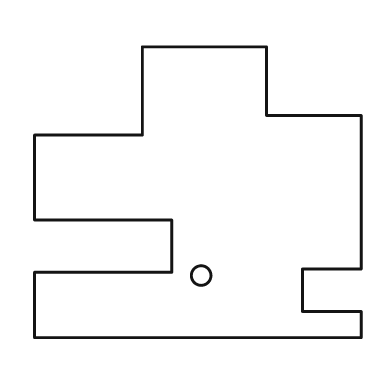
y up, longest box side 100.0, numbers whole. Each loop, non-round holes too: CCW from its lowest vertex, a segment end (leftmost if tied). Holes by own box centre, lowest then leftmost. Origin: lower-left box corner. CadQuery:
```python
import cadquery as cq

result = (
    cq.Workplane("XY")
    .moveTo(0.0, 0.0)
    .lineTo(100.0, 0.0)
    .lineTo(100.0, 8.0)
    .lineTo(82.0, 8.0)
    .lineTo(82.0, 21.0)
    .lineTo(100.0, 21.0)
    .lineTo(100.0, 68.0)
    .lineTo(71.0, 68.0)
    .lineTo(71.0, 89.0)
    .lineTo(33.0, 89.0)
    .lineTo(33.0, 62.0)
    .lineTo(0.0, 62.0)
    .lineTo(0.0, 36.0)
    .lineTo(42.0, 36.0)
    .lineTo(42.0, 20.0)
    .lineTo(0.0, 20.0)
    .close()
    .moveTo(51.0, 19.0)
    .circle(3.0)
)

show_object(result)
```